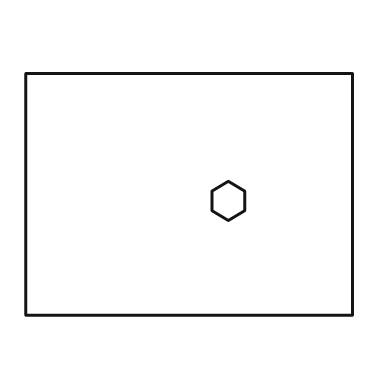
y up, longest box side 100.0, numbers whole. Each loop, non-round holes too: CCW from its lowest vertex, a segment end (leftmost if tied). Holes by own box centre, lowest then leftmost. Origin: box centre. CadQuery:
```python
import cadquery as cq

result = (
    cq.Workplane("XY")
    .moveTo(-50.0, -37.0)
    .lineTo(50.0, -37.0)
    .lineTo(50.0, 37.0)
    .lineTo(-50.0, 37.0)
    .close()
    .moveTo(12.0, -8.0)
    .lineTo(17.0, -5.0)
    .lineTo(17.0, 1.0)
    .lineTo(12.0, 4.0)
    .lineTo(7.0, 1.0)
    .lineTo(7.0, -5.0)
    .close()
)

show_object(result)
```